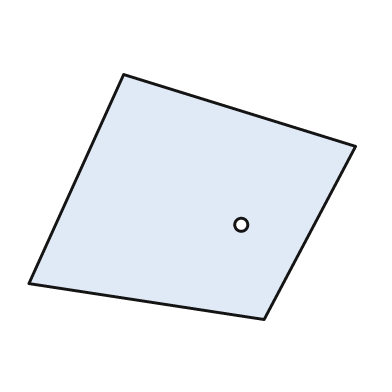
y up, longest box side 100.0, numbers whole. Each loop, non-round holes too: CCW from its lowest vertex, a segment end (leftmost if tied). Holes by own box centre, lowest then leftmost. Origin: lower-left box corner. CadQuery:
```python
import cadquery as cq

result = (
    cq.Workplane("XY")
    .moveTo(72.0, 0.0)
    .lineTo(100.0, 53.0)
    .lineTo(29.0, 75.0)
    .lineTo(0.0, 11.0)
    .close()
    .moveTo(65.0, 29.0)
    .circle(2.0)
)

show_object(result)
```